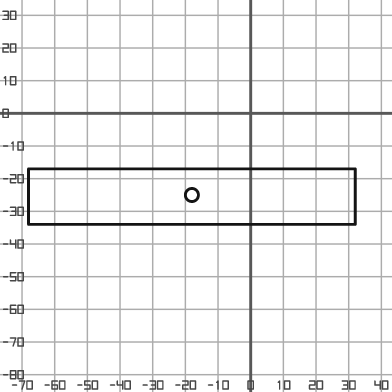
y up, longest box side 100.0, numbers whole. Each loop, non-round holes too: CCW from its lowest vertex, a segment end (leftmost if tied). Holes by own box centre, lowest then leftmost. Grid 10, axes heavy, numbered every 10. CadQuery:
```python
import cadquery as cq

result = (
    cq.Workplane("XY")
    .moveTo(-68.0, -34.0)
    .lineTo(32.0, -34.0)
    .lineTo(32.0, -17.0)
    .lineTo(-68.0, -17.0)
    .close()
    .moveTo(-18.0, -25.0)
    .circle(2.0)
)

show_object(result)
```